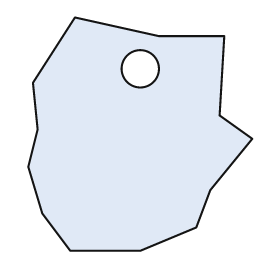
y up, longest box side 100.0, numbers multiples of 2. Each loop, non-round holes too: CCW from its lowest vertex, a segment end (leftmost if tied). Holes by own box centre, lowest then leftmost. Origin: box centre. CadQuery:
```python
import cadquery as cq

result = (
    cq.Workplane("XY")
    .moveTo(-30.0, -50.0)
    .lineTo(0.0, -50.0)
    .lineTo(24.0, -40.0)
    .lineTo(30.0, -24.0)
    .lineTo(48.0, -2.0)
    .lineTo(34.0, 8.0)
    .lineTo(36.0, 42.0)
    .lineTo(8.0, 42.0)
    .lineTo(-28.0, 50.0)
    .lineTo(-46.0, 22.0)
    .lineTo(-44.0, 2.0)
    .lineTo(-48.0, -14.0)
    .lineTo(-42.0, -34.0)
    .close()
    .moveTo(0.0, 28.0)
    .circle(8.0)
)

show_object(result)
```